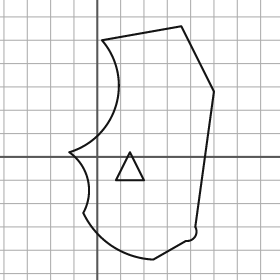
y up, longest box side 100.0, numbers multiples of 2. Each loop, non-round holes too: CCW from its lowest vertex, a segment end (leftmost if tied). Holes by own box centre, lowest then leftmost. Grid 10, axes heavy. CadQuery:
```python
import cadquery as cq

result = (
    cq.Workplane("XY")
    .moveTo(24.0, -44.0)
    .lineTo(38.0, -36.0)
    .threePointArc((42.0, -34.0), (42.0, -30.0))
    .lineTo(50.0, 28.0)
    .lineTo(36.0, 56.0)
    .lineTo(2.0, 50.0)
    .threePointArc((8.0, 22.0), (-12.0, 2.0))
    .threePointArc((-4.0, -10.0), (-6.0, -24.0))
    .threePointArc((6.0, -38.0), (24.0, -44.0))
    .close()
    .moveTo(8.0, -10.0)
    .lineTo(20.0, -10.0)
    .lineTo(14.0, 2.0)
    .close()
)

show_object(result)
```